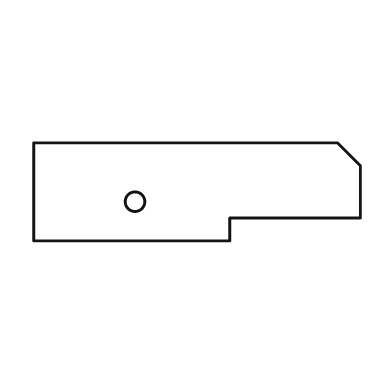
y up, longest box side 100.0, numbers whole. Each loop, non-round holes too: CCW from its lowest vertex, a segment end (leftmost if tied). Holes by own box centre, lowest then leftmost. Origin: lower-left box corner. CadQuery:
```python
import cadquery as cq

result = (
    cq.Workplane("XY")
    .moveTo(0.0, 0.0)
    .lineTo(60.0, 0.0)
    .lineTo(60.0, 7.0)
    .lineTo(100.0, 7.0)
    .lineTo(100.0, 23.0)
    .lineTo(93.0, 30.0)
    .lineTo(0.0, 30.0)
    .close()
    .moveTo(31.0, 12.0)
    .circle(3.0)
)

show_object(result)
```